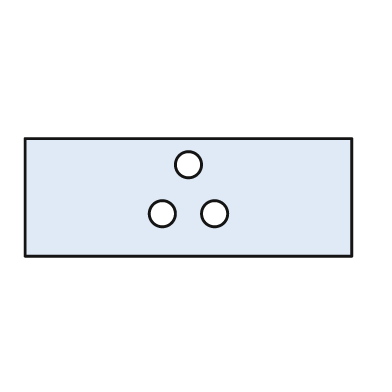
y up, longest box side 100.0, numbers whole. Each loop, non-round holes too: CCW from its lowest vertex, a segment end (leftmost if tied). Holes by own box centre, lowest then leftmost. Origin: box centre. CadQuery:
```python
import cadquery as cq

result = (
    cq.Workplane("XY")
    .moveTo(-50.0, -18.0)
    .lineTo(50.0, -18.0)
    .lineTo(50.0, 18.0)
    .lineTo(-50.0, 18.0)
    .close()
    .moveTo(-8.0, -5.0)
    .circle(4.0)
    .moveTo(8.0, -5.0)
    .circle(4.0)
    .moveTo(0.0, 10.0)
    .circle(4.0)
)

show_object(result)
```